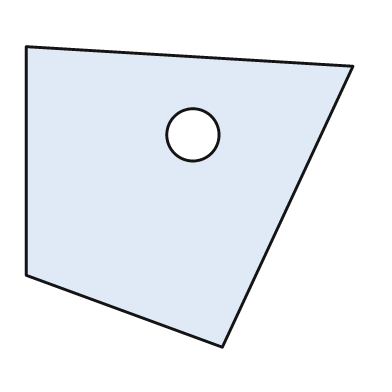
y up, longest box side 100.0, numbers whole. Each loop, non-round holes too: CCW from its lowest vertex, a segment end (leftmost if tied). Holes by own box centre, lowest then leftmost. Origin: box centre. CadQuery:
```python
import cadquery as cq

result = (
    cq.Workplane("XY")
    .moveTo(10.0, -46.0)
    .lineTo(50.0, 40.0)
    .lineTo(-50.0, 46.0)
    .lineTo(-50.0, -24.0)
    .close()
    .moveTo(1.0, 19.0)
    .circle(8.0)
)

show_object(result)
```